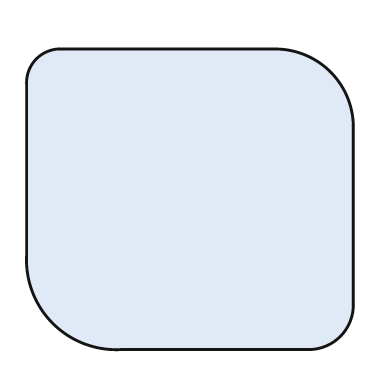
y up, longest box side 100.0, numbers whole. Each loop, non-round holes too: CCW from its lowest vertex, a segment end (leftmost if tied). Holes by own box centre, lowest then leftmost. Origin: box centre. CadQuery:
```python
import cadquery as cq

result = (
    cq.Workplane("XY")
    .moveTo(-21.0, -46.0)
    .lineTo(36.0, -46.0)
    .threePointArc((46.0, -42.0), (50.0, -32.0))
    .lineTo(50.0, 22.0)
    .threePointArc((43.0, 39.0), (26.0, 46.0))
    .lineTo(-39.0, 46.0)
    .threePointArc((-47.0, 43.0), (-50.0, 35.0))
    .lineTo(-50.0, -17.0)
    .threePointArc((-42.0, -38.0), (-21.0, -46.0))
    .close()
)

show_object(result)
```